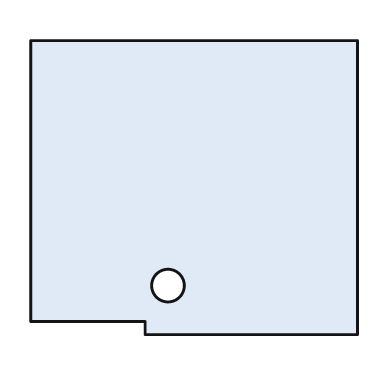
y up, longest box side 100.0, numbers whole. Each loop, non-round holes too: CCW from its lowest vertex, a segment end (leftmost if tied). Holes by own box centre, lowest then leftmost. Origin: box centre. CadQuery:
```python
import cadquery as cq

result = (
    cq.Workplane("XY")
    .moveTo(-15.0, -45.0)
    .lineTo(50.0, -45.0)
    .lineTo(50.0, 45.0)
    .lineTo(-50.0, 45.0)
    .lineTo(-50.0, -41.0)
    .lineTo(-15.0, -41.0)
    .close()
    .moveTo(-8.0, -30.0)
    .circle(5.0)
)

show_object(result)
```